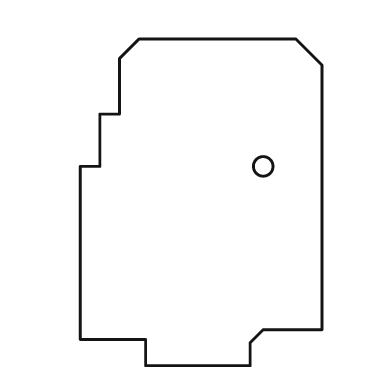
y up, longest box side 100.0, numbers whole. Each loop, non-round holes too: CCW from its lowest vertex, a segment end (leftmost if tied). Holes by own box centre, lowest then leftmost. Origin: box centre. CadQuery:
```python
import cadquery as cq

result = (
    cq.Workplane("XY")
    .moveTo(-17.0, -50.0)
    .lineTo(15.0, -50.0)
    .lineTo(15.0, -43.0)
    .lineTo(19.0, -39.0)
    .lineTo(37.0, -39.0)
    .lineTo(37.0, 42.0)
    .lineTo(29.0, 50.0)
    .lineTo(-19.0, 50.0)
    .lineTo(-25.0, 44.0)
    .lineTo(-25.0, 27.0)
    .lineTo(-31.0, 27.0)
    .lineTo(-31.0, 11.0)
    .lineTo(-37.0, 11.0)
    .lineTo(-37.0, -42.0)
    .lineTo(-17.0, -42.0)
    .close()
    .moveTo(19.0, 11.0)
    .circle(3.0)
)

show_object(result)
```